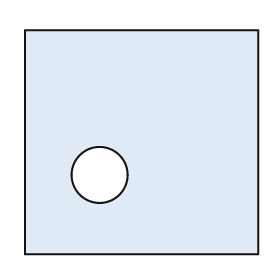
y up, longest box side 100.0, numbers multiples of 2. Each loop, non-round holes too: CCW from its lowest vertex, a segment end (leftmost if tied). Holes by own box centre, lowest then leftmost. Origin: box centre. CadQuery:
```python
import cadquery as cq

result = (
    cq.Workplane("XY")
    .moveTo(-50.0, -48.0)
    .lineTo(50.0, -48.0)
    .lineTo(50.0, 48.0)
    .lineTo(-50.0, 48.0)
    .close()
    .moveTo(-18.0, -14.0)
    .circle(12.0)
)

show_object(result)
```